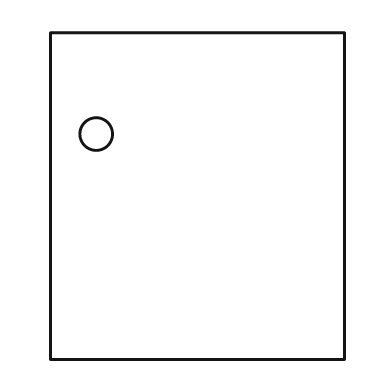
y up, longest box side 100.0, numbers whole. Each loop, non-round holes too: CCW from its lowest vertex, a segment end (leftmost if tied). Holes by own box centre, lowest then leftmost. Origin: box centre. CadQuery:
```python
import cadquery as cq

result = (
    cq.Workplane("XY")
    .moveTo(-45.0, -50.0)
    .lineTo(45.0, -50.0)
    .lineTo(45.0, 50.0)
    .lineTo(-45.0, 50.0)
    .close()
    .moveTo(-31.0, 19.0)
    .circle(5.0)
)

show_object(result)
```